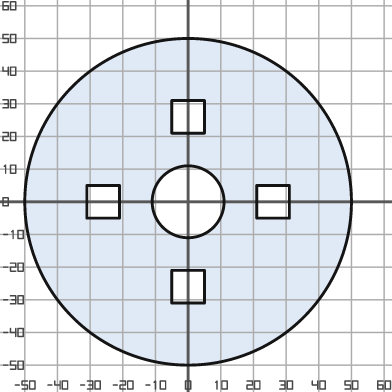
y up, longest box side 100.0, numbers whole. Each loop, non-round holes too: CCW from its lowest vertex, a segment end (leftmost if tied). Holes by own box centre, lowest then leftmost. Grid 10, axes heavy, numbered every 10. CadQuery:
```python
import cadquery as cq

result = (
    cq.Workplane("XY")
    .moveTo(0.0, 0.0)
    .circle(50.0)
    .moveTo(-5.0, -31.0)
    .lineTo(5.0, -31.0)
    .lineTo(5.0, -21.0)
    .lineTo(-5.0, -21.0)
    .close()
    .moveTo(-31.0, -5.0)
    .lineTo(-21.0, -5.0)
    .lineTo(-21.0, 5.0)
    .lineTo(-31.0, 5.0)
    .close()
    .moveTo(0.0, 0.0)
    .circle(11.0)
    .moveTo(21.0, -5.0)
    .lineTo(31.0, -5.0)
    .lineTo(31.0, 5.0)
    .lineTo(21.0, 5.0)
    .close()
    .moveTo(-5.0, 21.0)
    .lineTo(5.0, 21.0)
    .lineTo(5.0, 31.0)
    .lineTo(-5.0, 31.0)
    .close()
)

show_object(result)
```